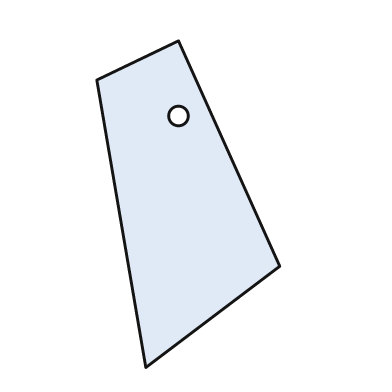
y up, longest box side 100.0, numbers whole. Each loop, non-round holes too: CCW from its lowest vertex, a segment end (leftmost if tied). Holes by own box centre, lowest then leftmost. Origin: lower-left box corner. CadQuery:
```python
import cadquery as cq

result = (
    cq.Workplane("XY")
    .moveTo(15.0, 0.0)
    .lineTo(56.0, 31.0)
    .lineTo(25.0, 100.0)
    .lineTo(0.0, 88.0)
    .close()
    .moveTo(25.0, 77.0)
    .circle(3.0)
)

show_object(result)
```